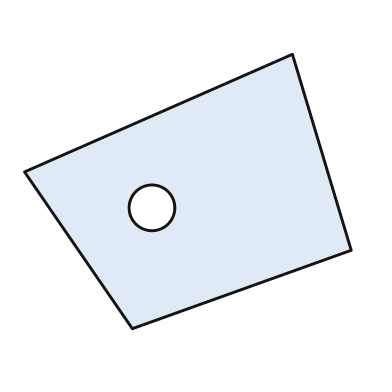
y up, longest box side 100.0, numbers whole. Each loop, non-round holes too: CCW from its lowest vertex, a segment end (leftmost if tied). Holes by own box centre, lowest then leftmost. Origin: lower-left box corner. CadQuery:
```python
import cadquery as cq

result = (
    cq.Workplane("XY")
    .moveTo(33.0, 0.0)
    .lineTo(100.0, 24.0)
    .lineTo(82.0, 84.0)
    .lineTo(0.0, 48.0)
    .close()
    .moveTo(39.0, 37.0)
    .circle(7.0)
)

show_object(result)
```